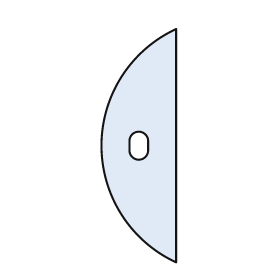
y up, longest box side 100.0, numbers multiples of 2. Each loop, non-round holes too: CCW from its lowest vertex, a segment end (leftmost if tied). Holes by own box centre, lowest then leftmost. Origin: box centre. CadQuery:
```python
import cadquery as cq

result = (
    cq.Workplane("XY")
    .moveTo(16.0, -50.0)
    .lineTo(16.0, 50.0)
    .threePointArc((-16.0, 0.0), (16.0, -50.0))
    .close()
    .moveTo(-4.0, -2.0)
    .threePointArc((0.0, -6.0), (4.0, -2.0))
    .lineTo(4.0, 2.0)
    .threePointArc((0.0, 6.0), (-4.0, 2.0))
    .close()
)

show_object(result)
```